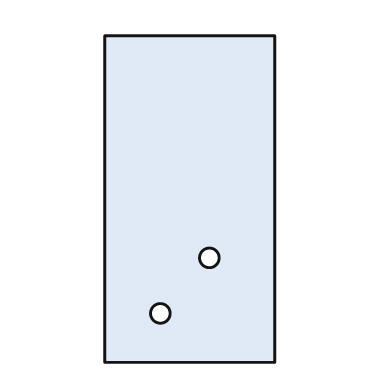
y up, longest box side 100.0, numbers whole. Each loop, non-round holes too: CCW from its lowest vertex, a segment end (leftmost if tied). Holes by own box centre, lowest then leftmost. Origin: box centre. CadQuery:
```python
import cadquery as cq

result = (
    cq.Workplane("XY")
    .moveTo(-26.0, -50.0)
    .lineTo(26.0, -50.0)
    .lineTo(26.0, 50.0)
    .lineTo(-26.0, 50.0)
    .close()
    .moveTo(-9.0, -35.0)
    .circle(3.0)
    .moveTo(6.0, -18.0)
    .circle(3.0)
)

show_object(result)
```